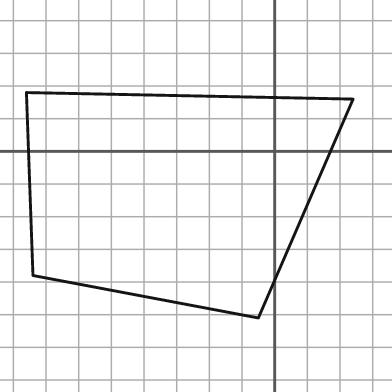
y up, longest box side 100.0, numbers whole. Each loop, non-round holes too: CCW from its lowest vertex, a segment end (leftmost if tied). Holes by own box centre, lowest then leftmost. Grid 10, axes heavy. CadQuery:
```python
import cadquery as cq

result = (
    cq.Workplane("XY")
    .moveTo(-5.0, -51.0)
    .lineTo(24.0, 16.0)
    .lineTo(-76.0, 18.0)
    .lineTo(-74.0, -38.0)
    .close()
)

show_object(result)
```